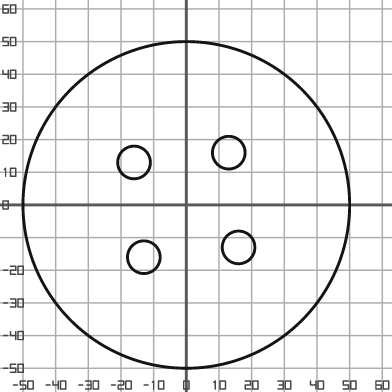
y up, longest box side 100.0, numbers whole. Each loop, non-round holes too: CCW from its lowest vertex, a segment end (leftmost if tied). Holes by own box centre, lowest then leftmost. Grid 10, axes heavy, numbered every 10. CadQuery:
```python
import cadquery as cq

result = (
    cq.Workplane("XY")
    .moveTo(0.0, 0.0)
    .circle(50.0)
    .moveTo(-13.0, -16.0)
    .circle(5.0)
    .moveTo(16.0, -13.0)
    .circle(5.0)
    .moveTo(-16.0, 13.0)
    .circle(5.0)
    .moveTo(13.0, 16.0)
    .circle(5.0)
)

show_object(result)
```